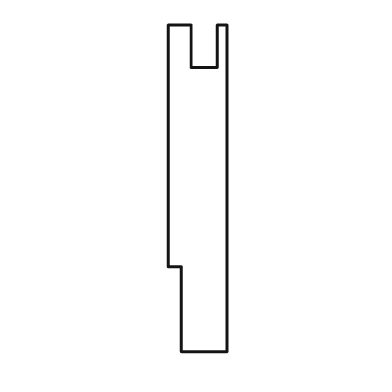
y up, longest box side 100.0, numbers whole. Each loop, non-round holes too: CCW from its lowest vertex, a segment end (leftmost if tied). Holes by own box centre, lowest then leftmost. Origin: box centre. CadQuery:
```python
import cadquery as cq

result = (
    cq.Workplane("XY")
    .moveTo(-5.0, -50.0)
    .lineTo(9.0, -50.0)
    .lineTo(9.0, 50.0)
    .lineTo(6.0, 50.0)
    .lineTo(6.0, 37.0)
    .lineTo(-2.0, 37.0)
    .lineTo(-2.0, 50.0)
    .lineTo(-9.0, 50.0)
    .lineTo(-9.0, -24.0)
    .lineTo(-5.0, -24.0)
    .close()
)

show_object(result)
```